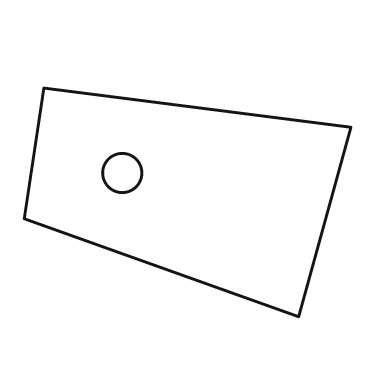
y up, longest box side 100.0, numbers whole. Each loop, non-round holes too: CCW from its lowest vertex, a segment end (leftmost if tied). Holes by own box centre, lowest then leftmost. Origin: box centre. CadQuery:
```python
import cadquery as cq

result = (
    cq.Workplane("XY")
    .moveTo(34.0, -35.0)
    .lineTo(50.0, 23.0)
    .lineTo(-44.0, 35.0)
    .lineTo(-50.0, -5.0)
    .close()
    .moveTo(-20.0, 9.0)
    .circle(6.0)
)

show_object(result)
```